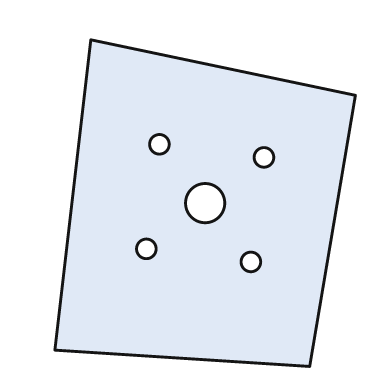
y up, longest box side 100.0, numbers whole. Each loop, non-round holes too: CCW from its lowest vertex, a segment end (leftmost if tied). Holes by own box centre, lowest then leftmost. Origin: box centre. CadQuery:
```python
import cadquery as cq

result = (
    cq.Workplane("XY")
    .moveTo(32.0, -50.0)
    .lineTo(46.0, 33.0)
    .lineTo(-35.0, 50.0)
    .lineTo(-46.0, -45.0)
    .close()
    .moveTo(14.0, -18.0)
    .circle(3.0)
    .moveTo(-18.0, -14.0)
    .circle(3.0)
    .moveTo(0.0, 0.0)
    .circle(6.0)
    .moveTo(18.0, 14.0)
    .circle(3.0)
    .moveTo(-14.0, 18.0)
    .circle(3.0)
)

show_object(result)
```